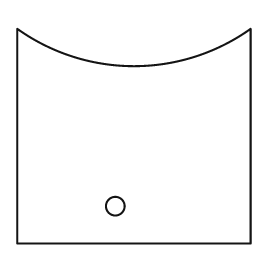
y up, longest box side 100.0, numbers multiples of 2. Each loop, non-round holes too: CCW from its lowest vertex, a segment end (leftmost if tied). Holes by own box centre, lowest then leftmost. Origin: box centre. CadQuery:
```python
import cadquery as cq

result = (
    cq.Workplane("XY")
    .moveTo(-50.0, -46.0)
    .lineTo(50.0, -46.0)
    .lineTo(50.0, 46.0)
    .threePointArc((0.0, 30.0), (-50.0, 46.0))
    .close()
    .moveTo(-8.0, -30.0)
    .circle(4.0)
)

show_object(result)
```